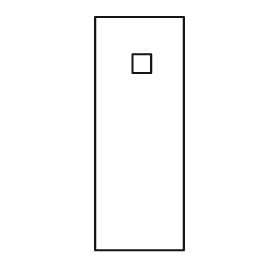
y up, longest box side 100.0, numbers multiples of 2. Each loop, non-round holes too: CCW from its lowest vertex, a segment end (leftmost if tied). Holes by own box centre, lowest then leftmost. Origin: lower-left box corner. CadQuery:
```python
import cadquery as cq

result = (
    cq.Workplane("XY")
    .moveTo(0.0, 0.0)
    .lineTo(38.0, 0.0)
    .lineTo(38.0, 100.0)
    .lineTo(0.0, 100.0)
    .close()
    .moveTo(16.0, 76.0)
    .lineTo(24.0, 76.0)
    .lineTo(24.0, 84.0)
    .lineTo(16.0, 84.0)
    .close()
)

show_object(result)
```